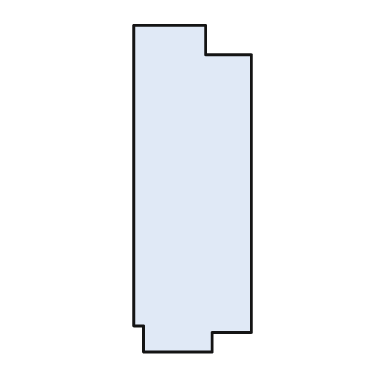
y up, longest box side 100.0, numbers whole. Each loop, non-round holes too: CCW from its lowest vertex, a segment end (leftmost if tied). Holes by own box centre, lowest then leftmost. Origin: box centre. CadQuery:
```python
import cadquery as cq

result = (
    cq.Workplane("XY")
    .moveTo(-15.0, -50.0)
    .lineTo(6.0, -50.0)
    .lineTo(6.0, -44.0)
    .lineTo(18.0, -44.0)
    .lineTo(18.0, 41.0)
    .lineTo(4.0, 41.0)
    .lineTo(4.0, 50.0)
    .lineTo(-18.0, 50.0)
    .lineTo(-18.0, -42.0)
    .lineTo(-15.0, -42.0)
    .close()
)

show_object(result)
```